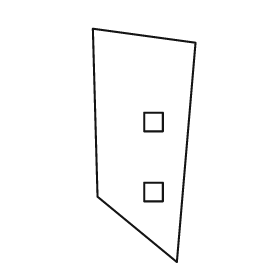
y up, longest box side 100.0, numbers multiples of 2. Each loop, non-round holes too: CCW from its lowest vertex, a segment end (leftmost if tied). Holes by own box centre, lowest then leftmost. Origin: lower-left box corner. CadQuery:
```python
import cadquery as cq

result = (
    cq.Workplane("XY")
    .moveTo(36.0, 0.0)
    .lineTo(44.0, 94.0)
    .lineTo(0.0, 100.0)
    .lineTo(2.0, 28.0)
    .close()
    .moveTo(22.0, 26.0)
    .lineTo(30.0, 26.0)
    .lineTo(30.0, 34.0)
    .lineTo(22.0, 34.0)
    .close()
    .moveTo(22.0, 56.0)
    .lineTo(30.0, 56.0)
    .lineTo(30.0, 64.0)
    .lineTo(22.0, 64.0)
    .close()
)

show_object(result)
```